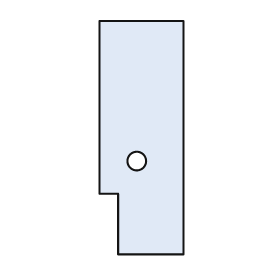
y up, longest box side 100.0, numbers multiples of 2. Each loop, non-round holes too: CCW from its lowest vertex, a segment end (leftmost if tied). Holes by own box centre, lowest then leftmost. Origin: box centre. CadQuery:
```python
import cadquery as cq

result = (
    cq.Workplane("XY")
    .moveTo(-10.0, -50.0)
    .lineTo(18.0, -50.0)
    .lineTo(18.0, 50.0)
    .lineTo(-18.0, 50.0)
    .lineTo(-18.0, -24.0)
    .lineTo(-10.0, -24.0)
    .close()
    .moveTo(-2.0, -10.0)
    .circle(4.0)
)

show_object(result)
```